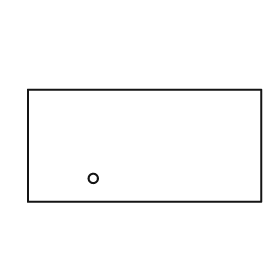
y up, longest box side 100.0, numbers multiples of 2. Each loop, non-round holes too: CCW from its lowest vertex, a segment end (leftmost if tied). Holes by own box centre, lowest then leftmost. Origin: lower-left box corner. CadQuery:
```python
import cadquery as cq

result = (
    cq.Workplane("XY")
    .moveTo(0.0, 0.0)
    .lineTo(100.0, 0.0)
    .lineTo(100.0, 48.0)
    .lineTo(0.0, 48.0)
    .close()
    .moveTo(28.0, 10.0)
    .circle(2.0)
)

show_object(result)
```